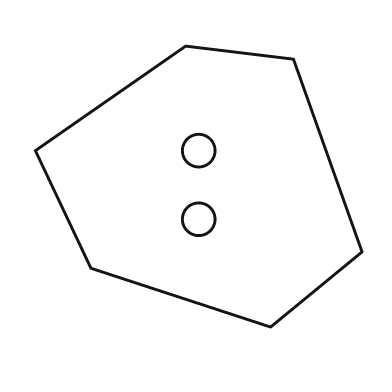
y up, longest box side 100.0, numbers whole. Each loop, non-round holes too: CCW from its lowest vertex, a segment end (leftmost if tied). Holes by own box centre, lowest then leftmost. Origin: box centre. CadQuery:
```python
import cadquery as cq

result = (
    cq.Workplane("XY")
    .moveTo(22.0, -43.0)
    .lineTo(50.0, -20.0)
    .lineTo(29.0, 39.0)
    .lineTo(-4.0, 43.0)
    .lineTo(-50.0, 11.0)
    .lineTo(-33.0, -25.0)
    .close()
    .moveTo(0.0, -10.0)
    .circle(5.0)
    .moveTo(0.0, 11.0)
    .circle(5.0)
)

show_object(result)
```